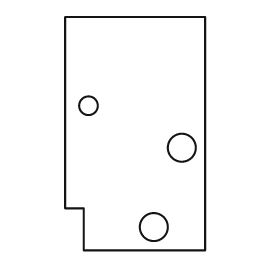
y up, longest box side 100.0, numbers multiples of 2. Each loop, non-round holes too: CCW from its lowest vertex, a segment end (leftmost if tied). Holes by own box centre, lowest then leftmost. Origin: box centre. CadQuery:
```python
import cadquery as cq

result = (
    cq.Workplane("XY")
    .moveTo(-22.0, -50.0)
    .lineTo(30.0, -50.0)
    .lineTo(30.0, 50.0)
    .lineTo(-30.0, 50.0)
    .lineTo(-30.0, -32.0)
    .lineTo(-22.0, -32.0)
    .close()
    .moveTo(8.0, -40.0)
    .circle(6.0)
    .moveTo(20.0, -6.0)
    .circle(6.0)
    .moveTo(-20.0, 12.0)
    .circle(4.0)
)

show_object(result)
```